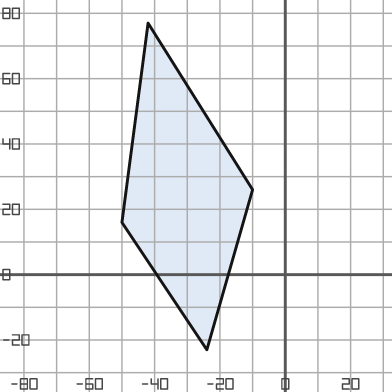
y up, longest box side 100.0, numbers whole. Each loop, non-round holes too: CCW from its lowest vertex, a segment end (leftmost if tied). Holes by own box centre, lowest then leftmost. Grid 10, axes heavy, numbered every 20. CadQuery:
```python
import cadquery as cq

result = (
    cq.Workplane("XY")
    .moveTo(-24.0, -23.0)
    .lineTo(-10.0, 26.0)
    .lineTo(-42.0, 77.0)
    .lineTo(-50.0, 16.0)
    .close()
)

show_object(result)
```